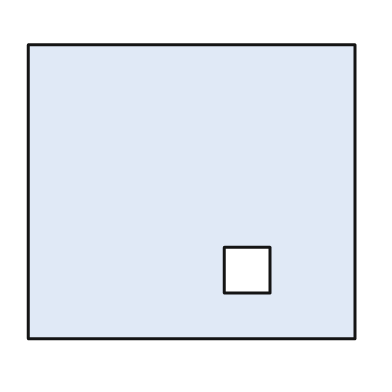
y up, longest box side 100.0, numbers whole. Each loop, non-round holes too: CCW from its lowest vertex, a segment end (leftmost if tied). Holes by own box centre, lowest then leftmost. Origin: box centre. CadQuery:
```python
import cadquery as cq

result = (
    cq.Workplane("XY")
    .moveTo(-50.0, -45.0)
    .lineTo(50.0, -45.0)
    .lineTo(50.0, 45.0)
    .lineTo(-50.0, 45.0)
    .close()
    .moveTo(10.0, -31.0)
    .lineTo(24.0, -31.0)
    .lineTo(24.0, -17.0)
    .lineTo(10.0, -17.0)
    .close()
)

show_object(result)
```